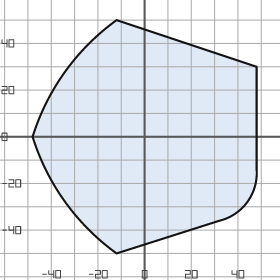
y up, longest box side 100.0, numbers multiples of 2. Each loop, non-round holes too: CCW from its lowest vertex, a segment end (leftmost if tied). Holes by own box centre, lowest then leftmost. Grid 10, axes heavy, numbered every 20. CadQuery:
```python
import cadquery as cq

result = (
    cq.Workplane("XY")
    .moveTo(-12.0, -50.0)
    .lineTo(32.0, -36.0)
    .threePointArc((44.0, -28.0), (48.0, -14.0))
    .lineTo(48.0, 30.0)
    .lineTo(-12.0, 50.0)
    .threePointArc((-34.0, 28.0), (-48.0, 0.0))
    .threePointArc((-34.0, -28.0), (-12.0, -50.0))
    .close()
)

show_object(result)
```